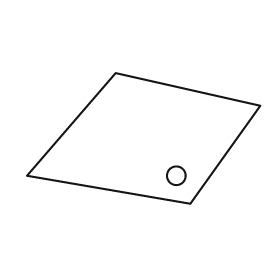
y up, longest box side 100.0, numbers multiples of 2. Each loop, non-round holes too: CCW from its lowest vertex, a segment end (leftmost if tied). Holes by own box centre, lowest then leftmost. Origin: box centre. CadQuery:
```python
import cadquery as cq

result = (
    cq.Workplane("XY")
    .moveTo(20.0, -28.0)
    .lineTo(50.0, 14.0)
    .lineTo(-12.0, 28.0)
    .lineTo(-50.0, -16.0)
    .close()
    .moveTo(14.0, -16.0)
    .circle(4.0)
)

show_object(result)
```